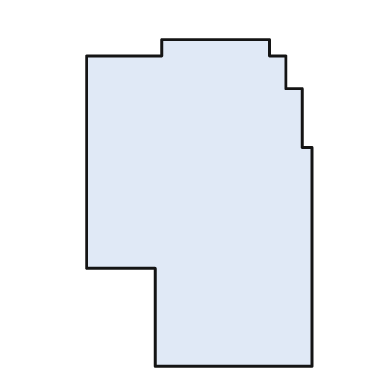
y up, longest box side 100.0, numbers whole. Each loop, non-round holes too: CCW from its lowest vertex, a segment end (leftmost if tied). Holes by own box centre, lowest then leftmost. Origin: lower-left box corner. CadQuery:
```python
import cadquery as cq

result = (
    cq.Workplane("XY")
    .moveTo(21.0, 0.0)
    .lineTo(69.0, 0.0)
    .lineTo(69.0, 67.0)
    .lineTo(66.0, 67.0)
    .lineTo(66.0, 85.0)
    .lineTo(61.0, 85.0)
    .lineTo(61.0, 95.0)
    .lineTo(56.0, 95.0)
    .lineTo(56.0, 100.0)
    .lineTo(23.0, 100.0)
    .lineTo(23.0, 95.0)
    .lineTo(0.0, 95.0)
    .lineTo(0.0, 30.0)
    .lineTo(21.0, 30.0)
    .close()
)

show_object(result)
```